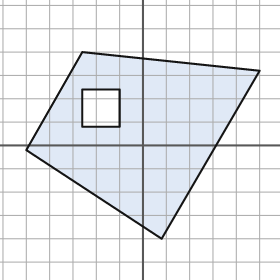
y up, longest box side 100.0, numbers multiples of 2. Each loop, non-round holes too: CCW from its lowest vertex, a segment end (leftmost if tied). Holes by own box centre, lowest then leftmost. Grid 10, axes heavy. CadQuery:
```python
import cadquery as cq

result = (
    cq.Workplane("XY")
    .moveTo(8.0, -40.0)
    .lineTo(50.0, 32.0)
    .lineTo(-26.0, 40.0)
    .lineTo(-50.0, -2.0)
    .close()
    .moveTo(-26.0, 8.0)
    .lineTo(-10.0, 8.0)
    .lineTo(-10.0, 24.0)
    .lineTo(-26.0, 24.0)
    .close()
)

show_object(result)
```